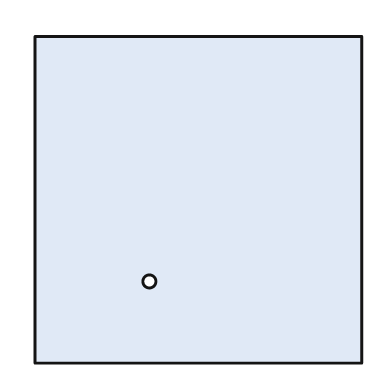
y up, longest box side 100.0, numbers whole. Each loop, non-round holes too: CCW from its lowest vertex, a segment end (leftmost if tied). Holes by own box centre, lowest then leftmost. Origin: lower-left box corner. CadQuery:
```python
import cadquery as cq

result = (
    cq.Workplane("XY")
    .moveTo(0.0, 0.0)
    .lineTo(100.0, 0.0)
    .lineTo(100.0, 100.0)
    .lineTo(0.0, 100.0)
    .close()
    .moveTo(35.0, 25.0)
    .circle(2.0)
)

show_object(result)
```